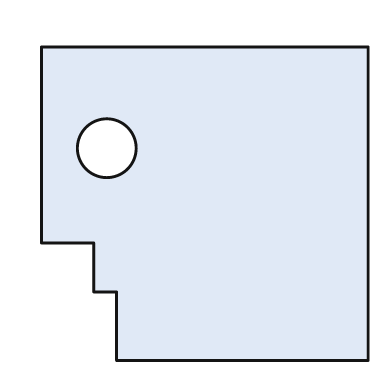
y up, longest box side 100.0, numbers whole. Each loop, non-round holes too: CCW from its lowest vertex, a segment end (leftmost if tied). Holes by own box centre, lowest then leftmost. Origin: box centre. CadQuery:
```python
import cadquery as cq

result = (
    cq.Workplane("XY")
    .moveTo(-27.0, -48.0)
    .lineTo(50.0, -48.0)
    .lineTo(50.0, 48.0)
    .lineTo(-50.0, 48.0)
    .lineTo(-50.0, -12.0)
    .lineTo(-34.0, -12.0)
    .lineTo(-34.0, -27.0)
    .lineTo(-27.0, -27.0)
    .close()
    .moveTo(-30.0, 17.0)
    .circle(9.0)
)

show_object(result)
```